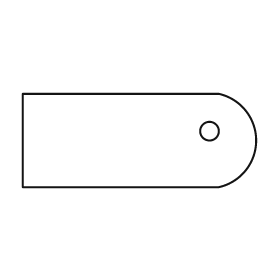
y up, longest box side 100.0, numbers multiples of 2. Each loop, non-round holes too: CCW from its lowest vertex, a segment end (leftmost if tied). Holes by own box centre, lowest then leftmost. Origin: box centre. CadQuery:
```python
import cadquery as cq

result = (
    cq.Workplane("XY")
    .moveTo(-50.0, -20.0)
    .lineTo(34.0, -20.0)
    .threePointArc((50.0, 0.0), (34.0, 20.0))
    .lineTo(-50.0, 20.0)
    .close()
    .moveTo(30.0, 4.0)
    .circle(4.0)
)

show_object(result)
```